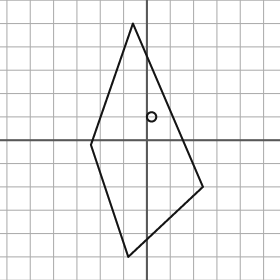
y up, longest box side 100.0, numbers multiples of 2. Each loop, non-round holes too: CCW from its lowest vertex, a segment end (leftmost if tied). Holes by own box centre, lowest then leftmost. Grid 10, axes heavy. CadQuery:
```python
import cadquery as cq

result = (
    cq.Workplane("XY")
    .moveTo(-8.0, -50.0)
    .lineTo(24.0, -20.0)
    .lineTo(-6.0, 50.0)
    .lineTo(-24.0, -2.0)
    .close()
    .moveTo(2.0, 10.0)
    .circle(2.0)
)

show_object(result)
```